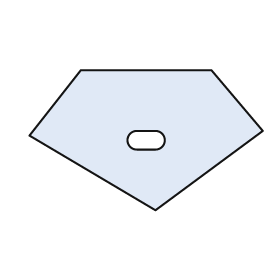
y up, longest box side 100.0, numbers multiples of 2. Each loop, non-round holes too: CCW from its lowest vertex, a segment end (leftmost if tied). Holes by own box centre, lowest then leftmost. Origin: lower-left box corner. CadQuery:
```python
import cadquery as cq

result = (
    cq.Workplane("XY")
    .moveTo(54.0, 0.0)
    .lineTo(100.0, 34.0)
    .lineTo(78.0, 60.0)
    .lineTo(22.0, 60.0)
    .lineTo(0.0, 32.0)
    .close()
    .moveTo(46.0, 26.0)
    .lineTo(54.0, 26.0)
    .threePointArc((58.0, 30.0), (54.0, 34.0))
    .lineTo(46.0, 34.0)
    .threePointArc((42.0, 30.0), (46.0, 26.0))
    .close()
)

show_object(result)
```